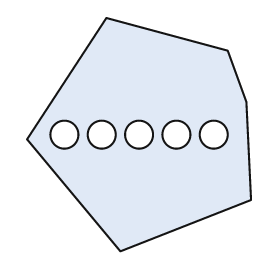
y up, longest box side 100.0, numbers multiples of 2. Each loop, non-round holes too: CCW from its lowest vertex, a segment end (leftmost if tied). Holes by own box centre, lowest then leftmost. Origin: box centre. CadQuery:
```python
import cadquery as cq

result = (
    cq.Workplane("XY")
    .moveTo(-8.0, -50.0)
    .lineTo(48.0, -28.0)
    .lineTo(46.0, 14.0)
    .lineTo(38.0, 36.0)
    .lineTo(-14.0, 50.0)
    .lineTo(-48.0, -2.0)
    .close()
    .moveTo(-32.0, 0.0)
    .circle(6.0)
    .moveTo(-16.0, 0.0)
    .circle(6.0)
    .moveTo(0.0, 0.0)
    .circle(6.0)
    .moveTo(16.0, 0.0)
    .circle(6.0)
    .moveTo(32.0, 0.0)
    .circle(6.0)
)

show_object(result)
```